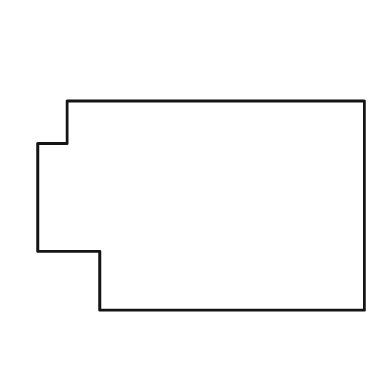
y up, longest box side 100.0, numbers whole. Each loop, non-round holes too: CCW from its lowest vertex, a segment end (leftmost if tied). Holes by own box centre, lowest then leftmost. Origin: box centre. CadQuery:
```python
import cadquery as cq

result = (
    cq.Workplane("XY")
    .moveTo(-31.0, -32.0)
    .lineTo(50.0, -32.0)
    .lineTo(50.0, 32.0)
    .lineTo(-41.0, 32.0)
    .lineTo(-41.0, 19.0)
    .lineTo(-50.0, 19.0)
    .lineTo(-50.0, -14.0)
    .lineTo(-31.0, -14.0)
    .close()
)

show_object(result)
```